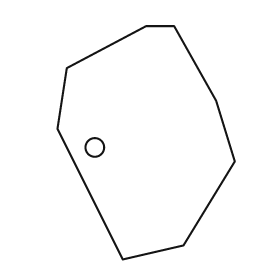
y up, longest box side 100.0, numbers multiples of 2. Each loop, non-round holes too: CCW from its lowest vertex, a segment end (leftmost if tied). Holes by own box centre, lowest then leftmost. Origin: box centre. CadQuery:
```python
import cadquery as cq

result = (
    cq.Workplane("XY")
    .moveTo(-10.0, -50.0)
    .lineTo(16.0, -44.0)
    .lineTo(38.0, -8.0)
    .lineTo(30.0, 18.0)
    .lineTo(12.0, 50.0)
    .lineTo(0.0, 50.0)
    .lineTo(-34.0, 32.0)
    .lineTo(-38.0, 6.0)
    .close()
    .moveTo(-22.0, -2.0)
    .circle(4.0)
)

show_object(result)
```